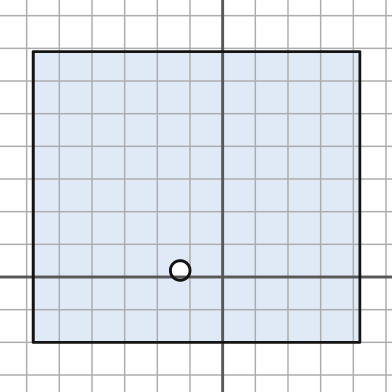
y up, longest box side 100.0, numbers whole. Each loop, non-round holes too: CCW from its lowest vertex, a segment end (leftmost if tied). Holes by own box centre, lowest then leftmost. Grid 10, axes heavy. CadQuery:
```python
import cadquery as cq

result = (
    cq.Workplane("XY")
    .moveTo(-58.0, -20.0)
    .lineTo(42.0, -20.0)
    .lineTo(42.0, 69.0)
    .lineTo(-58.0, 69.0)
    .close()
    .moveTo(-13.0, 2.0)
    .circle(3.0)
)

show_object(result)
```